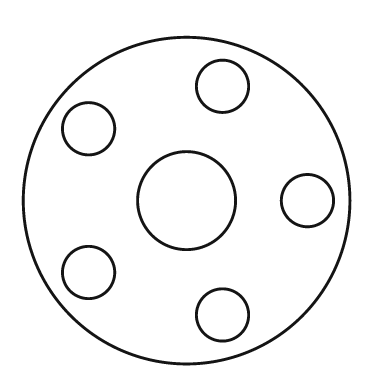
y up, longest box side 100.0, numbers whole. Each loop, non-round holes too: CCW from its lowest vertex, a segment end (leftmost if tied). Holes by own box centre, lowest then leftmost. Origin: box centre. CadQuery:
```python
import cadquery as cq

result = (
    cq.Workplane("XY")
    .moveTo(0.0, 0.0)
    .circle(50.0)
    .moveTo(11.0, -35.0)
    .circle(8.0)
    .moveTo(-30.0, -22.0)
    .circle(8.0)
    .moveTo(0.0, 0.0)
    .circle(15.0)
    .moveTo(37.0, 0.0)
    .circle(8.0)
    .moveTo(-30.0, 22.0)
    .circle(8.0)
    .moveTo(11.0, 35.0)
    .circle(8.0)
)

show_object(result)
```